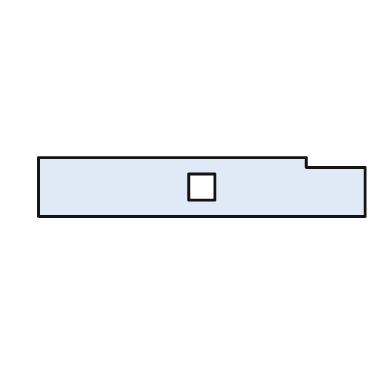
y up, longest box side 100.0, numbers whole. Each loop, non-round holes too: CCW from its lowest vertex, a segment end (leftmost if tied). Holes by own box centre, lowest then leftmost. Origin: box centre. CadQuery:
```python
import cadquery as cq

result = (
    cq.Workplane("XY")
    .moveTo(-50.0, -9.0)
    .lineTo(50.0, -9.0)
    .lineTo(50.0, 6.0)
    .lineTo(32.0, 6.0)
    .lineTo(32.0, 9.0)
    .lineTo(-50.0, 9.0)
    .close()
    .moveTo(-4.0, -4.0)
    .lineTo(4.0, -4.0)
    .lineTo(4.0, 4.0)
    .lineTo(-4.0, 4.0)
    .close()
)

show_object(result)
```